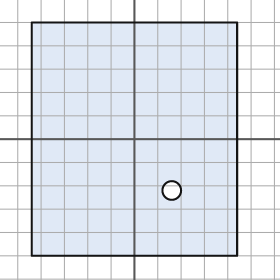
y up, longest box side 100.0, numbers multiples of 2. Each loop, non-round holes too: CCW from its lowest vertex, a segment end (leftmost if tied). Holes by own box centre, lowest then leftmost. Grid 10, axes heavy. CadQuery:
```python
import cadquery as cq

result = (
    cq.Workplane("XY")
    .moveTo(-44.0, -50.0)
    .lineTo(44.0, -50.0)
    .lineTo(44.0, 50.0)
    .lineTo(-44.0, 50.0)
    .close()
    .moveTo(16.0, -22.0)
    .circle(4.0)
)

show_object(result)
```